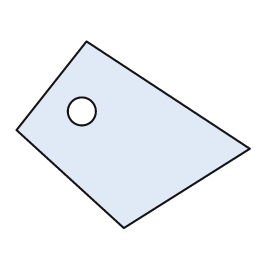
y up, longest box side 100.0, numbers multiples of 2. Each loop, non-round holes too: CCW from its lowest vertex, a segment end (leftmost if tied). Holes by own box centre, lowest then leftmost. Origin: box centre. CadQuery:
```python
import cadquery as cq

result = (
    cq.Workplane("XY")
    .moveTo(-4.0, -40.0)
    .lineTo(50.0, -6.0)
    .lineTo(-20.0, 40.0)
    .lineTo(-50.0, 2.0)
    .close()
    .moveTo(-22.0, 10.0)
    .circle(6.0)
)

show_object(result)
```